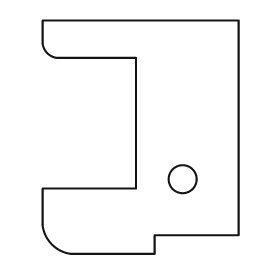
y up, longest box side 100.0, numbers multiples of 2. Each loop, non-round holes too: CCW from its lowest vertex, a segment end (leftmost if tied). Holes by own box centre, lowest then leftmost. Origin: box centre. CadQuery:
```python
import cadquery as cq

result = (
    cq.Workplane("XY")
    .moveTo(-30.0, -50.0)
    .lineTo(6.0, -50.0)
    .lineTo(6.0, -42.0)
    .lineTo(42.0, -42.0)
    .lineTo(42.0, 50.0)
    .lineTo(-42.0, 50.0)
    .lineTo(-42.0, 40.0)
    .threePointArc((-40.0, 36.0), (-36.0, 34.0))
    .lineTo(-2.0, 34.0)
    .lineTo(-2.0, -22.0)
    .lineTo(-42.0, -22.0)
    .lineTo(-42.0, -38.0)
    .threePointArc((-38.0, -46.0), (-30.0, -50.0))
    .close()
    .moveTo(18.0, -18.0)
    .circle(6.0)
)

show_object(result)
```